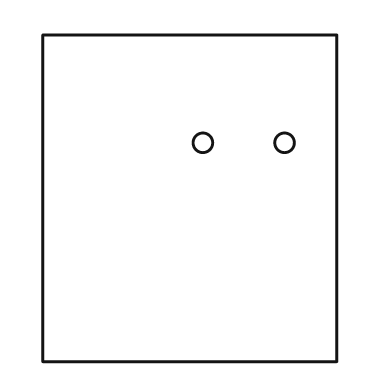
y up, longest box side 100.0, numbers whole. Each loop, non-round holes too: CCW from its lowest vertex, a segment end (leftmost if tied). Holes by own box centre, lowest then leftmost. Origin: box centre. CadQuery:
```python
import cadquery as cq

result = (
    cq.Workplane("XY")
    .moveTo(-45.0, -50.0)
    .lineTo(45.0, -50.0)
    .lineTo(45.0, 50.0)
    .lineTo(-45.0, 50.0)
    .close()
    .moveTo(4.0, 17.0)
    .circle(3.0)
    .moveTo(29.0, 17.0)
    .circle(3.0)
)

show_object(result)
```